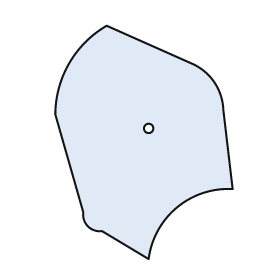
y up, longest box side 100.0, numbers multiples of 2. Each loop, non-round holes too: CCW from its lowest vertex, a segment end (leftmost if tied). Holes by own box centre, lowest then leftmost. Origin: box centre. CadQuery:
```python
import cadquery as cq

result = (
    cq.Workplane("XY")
    .moveTo(2.0, -50.0)
    .threePointArc((14.0, -28.0), (38.0, -20.0))
    .lineTo(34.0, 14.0)
    .threePointArc((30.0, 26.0), (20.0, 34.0))
    .lineTo(-16.0, 50.0)
    .threePointArc((-32.0, 34.0), (-38.0, 12.0))
    .lineTo(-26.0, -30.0)
    .threePointArc((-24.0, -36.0), (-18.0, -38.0))
    .close()
    .moveTo(2.0, 6.0)
    .circle(2.0)
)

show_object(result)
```